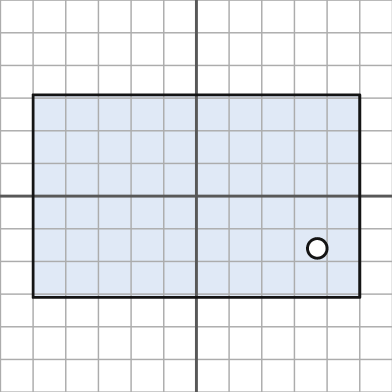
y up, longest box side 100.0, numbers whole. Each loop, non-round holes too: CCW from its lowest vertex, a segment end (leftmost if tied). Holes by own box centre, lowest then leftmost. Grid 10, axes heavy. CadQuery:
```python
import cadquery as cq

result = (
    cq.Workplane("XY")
    .moveTo(-50.0, -31.0)
    .lineTo(50.0, -31.0)
    .lineTo(50.0, 31.0)
    .lineTo(-50.0, 31.0)
    .close()
    .moveTo(37.0, -16.0)
    .circle(3.0)
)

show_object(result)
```